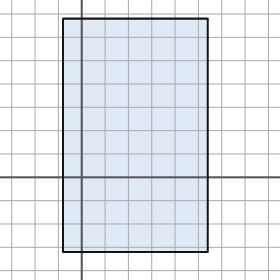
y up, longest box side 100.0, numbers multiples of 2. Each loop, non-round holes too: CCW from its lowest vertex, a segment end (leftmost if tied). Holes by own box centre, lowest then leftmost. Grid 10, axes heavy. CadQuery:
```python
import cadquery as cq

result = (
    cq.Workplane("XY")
    .moveTo(-8.0, -32.0)
    .lineTo(54.0, -32.0)
    .lineTo(54.0, 68.0)
    .lineTo(-8.0, 68.0)
    .close()
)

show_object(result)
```